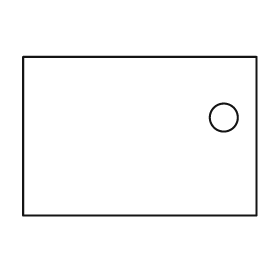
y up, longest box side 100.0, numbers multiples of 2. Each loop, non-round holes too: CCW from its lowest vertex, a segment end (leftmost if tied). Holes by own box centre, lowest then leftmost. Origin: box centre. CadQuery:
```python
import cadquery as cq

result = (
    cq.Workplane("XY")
    .moveTo(-50.0, -34.0)
    .lineTo(50.0, -34.0)
    .lineTo(50.0, 34.0)
    .lineTo(-50.0, 34.0)
    .close()
    .moveTo(36.0, 8.0)
    .circle(6.0)
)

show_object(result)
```